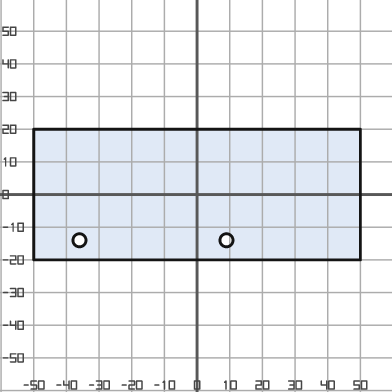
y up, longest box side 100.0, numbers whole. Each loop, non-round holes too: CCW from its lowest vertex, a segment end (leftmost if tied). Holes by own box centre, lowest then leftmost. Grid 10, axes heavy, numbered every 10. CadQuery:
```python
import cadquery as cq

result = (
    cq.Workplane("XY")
    .moveTo(-50.0, -20.0)
    .lineTo(50.0, -20.0)
    .lineTo(50.0, 20.0)
    .lineTo(-50.0, 20.0)
    .close()
    .moveTo(-36.0, -14.0)
    .circle(2.0)
    .moveTo(9.0, -14.0)
    .circle(2.0)
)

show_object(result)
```